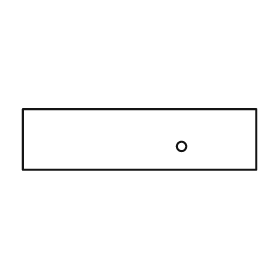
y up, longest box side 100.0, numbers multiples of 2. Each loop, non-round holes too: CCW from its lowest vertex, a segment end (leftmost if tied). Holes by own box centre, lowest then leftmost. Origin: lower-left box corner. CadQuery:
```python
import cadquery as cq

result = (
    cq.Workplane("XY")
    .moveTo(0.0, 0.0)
    .lineTo(100.0, 0.0)
    .lineTo(100.0, 26.0)
    .lineTo(0.0, 26.0)
    .close()
    .moveTo(68.0, 10.0)
    .circle(2.0)
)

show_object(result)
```